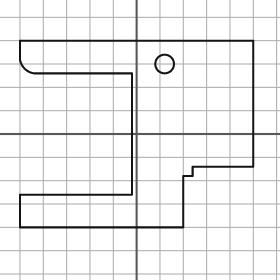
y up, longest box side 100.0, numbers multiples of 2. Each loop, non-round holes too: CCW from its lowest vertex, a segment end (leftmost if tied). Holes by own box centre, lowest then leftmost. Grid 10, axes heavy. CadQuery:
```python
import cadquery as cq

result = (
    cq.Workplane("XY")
    .moveTo(-50.0, -40.0)
    .lineTo(20.0, -40.0)
    .lineTo(20.0, -18.0)
    .lineTo(24.0, -18.0)
    .lineTo(24.0, -14.0)
    .lineTo(50.0, -14.0)
    .lineTo(50.0, 40.0)
    .lineTo(-50.0, 40.0)
    .lineTo(-50.0, 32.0)
    .threePointArc((-48.0, 28.0), (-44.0, 26.0))
    .lineTo(-2.0, 26.0)
    .lineTo(-2.0, -26.0)
    .lineTo(-50.0, -26.0)
    .close()
    .moveTo(12.0, 30.0)
    .circle(4.0)
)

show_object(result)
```